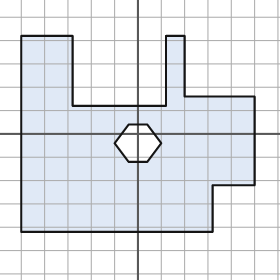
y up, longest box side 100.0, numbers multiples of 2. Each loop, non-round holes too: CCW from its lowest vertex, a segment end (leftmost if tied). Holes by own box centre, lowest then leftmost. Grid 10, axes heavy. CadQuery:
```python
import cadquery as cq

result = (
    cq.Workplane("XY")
    .moveTo(-50.0, -42.0)
    .lineTo(32.0, -42.0)
    .lineTo(32.0, -22.0)
    .lineTo(50.0, -22.0)
    .lineTo(50.0, 16.0)
    .lineTo(20.0, 16.0)
    .lineTo(20.0, 42.0)
    .lineTo(12.0, 42.0)
    .lineTo(12.0, 12.0)
    .lineTo(-28.0, 12.0)
    .lineTo(-28.0, 42.0)
    .lineTo(-50.0, 42.0)
    .close()
    .moveTo(-4.0, -12.0)
    .lineTo(4.0, -12.0)
    .lineTo(10.0, -4.0)
    .lineTo(4.0, 4.0)
    .lineTo(-4.0, 4.0)
    .lineTo(-10.0, -4.0)
    .close()
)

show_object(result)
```